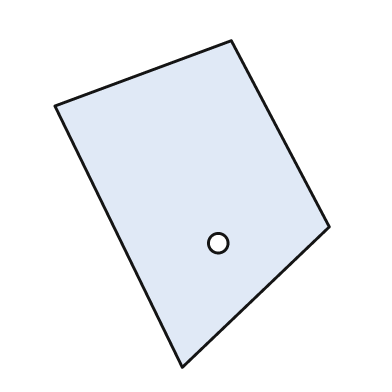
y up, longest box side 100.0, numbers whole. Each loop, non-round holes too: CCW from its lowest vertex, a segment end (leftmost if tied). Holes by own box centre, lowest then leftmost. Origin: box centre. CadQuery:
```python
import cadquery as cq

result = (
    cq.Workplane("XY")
    .moveTo(-3.0, -50.0)
    .lineTo(42.0, -7.0)
    .lineTo(12.0, 50.0)
    .lineTo(-42.0, 30.0)
    .close()
    .moveTo(8.0, -12.0)
    .circle(3.0)
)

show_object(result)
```